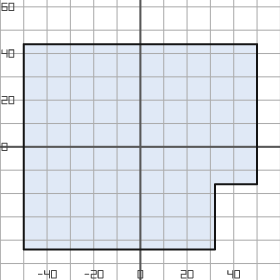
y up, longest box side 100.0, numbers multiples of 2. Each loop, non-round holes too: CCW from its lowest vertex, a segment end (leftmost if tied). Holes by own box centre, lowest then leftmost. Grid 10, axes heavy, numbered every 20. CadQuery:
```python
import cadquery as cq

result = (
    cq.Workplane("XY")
    .moveTo(-50.0, -44.0)
    .lineTo(32.0, -44.0)
    .lineTo(32.0, -16.0)
    .lineTo(50.0, -16.0)
    .lineTo(50.0, 44.0)
    .lineTo(-50.0, 44.0)
    .close()
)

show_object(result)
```